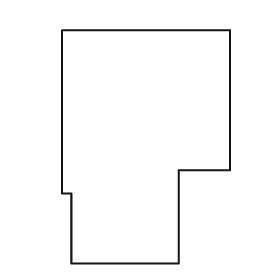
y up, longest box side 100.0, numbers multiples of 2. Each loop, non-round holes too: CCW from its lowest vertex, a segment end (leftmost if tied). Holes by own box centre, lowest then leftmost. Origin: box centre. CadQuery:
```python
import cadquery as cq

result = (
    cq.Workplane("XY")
    .moveTo(-32.0, -50.0)
    .lineTo(14.0, -50.0)
    .lineTo(14.0, -10.0)
    .lineTo(36.0, -10.0)
    .lineTo(36.0, 50.0)
    .lineTo(-36.0, 50.0)
    .lineTo(-36.0, -20.0)
    .lineTo(-32.0, -20.0)
    .close()
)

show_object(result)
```